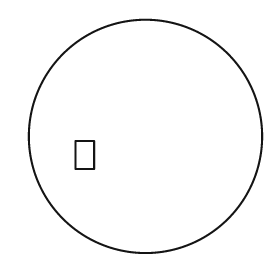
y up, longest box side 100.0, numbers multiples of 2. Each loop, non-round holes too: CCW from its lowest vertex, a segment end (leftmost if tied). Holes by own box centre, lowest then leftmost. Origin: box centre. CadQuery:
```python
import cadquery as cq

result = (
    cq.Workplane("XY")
    .moveTo(0.0, 0.0)
    .circle(50.0)
    .moveTo(-30.0, -14.0)
    .lineTo(-22.0, -14.0)
    .lineTo(-22.0, -2.0)
    .lineTo(-30.0, -2.0)
    .close()
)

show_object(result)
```